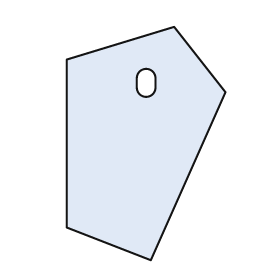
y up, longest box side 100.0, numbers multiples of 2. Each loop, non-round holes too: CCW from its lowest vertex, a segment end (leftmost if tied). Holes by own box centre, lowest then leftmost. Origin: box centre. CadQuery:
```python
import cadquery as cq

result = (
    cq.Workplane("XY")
    .moveTo(2.0, -50.0)
    .lineTo(34.0, 22.0)
    .lineTo(12.0, 50.0)
    .lineTo(-34.0, 36.0)
    .lineTo(-34.0, -36.0)
    .close()
    .moveTo(-4.0, 24.0)
    .threePointArc((0.0, 20.0), (4.0, 24.0))
    .lineTo(4.0, 28.0)
    .threePointArc((0.0, 32.0), (-4.0, 28.0))
    .close()
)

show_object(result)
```